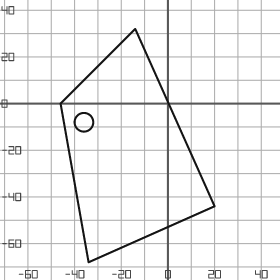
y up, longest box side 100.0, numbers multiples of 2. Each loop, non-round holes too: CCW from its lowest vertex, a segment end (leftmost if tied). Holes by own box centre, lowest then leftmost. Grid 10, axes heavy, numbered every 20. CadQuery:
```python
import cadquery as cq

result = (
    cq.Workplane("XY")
    .moveTo(-34.0, -68.0)
    .lineTo(20.0, -44.0)
    .lineTo(-14.0, 32.0)
    .lineTo(-46.0, 0.0)
    .close()
    .moveTo(-36.0, -8.0)
    .circle(4.0)
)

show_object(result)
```